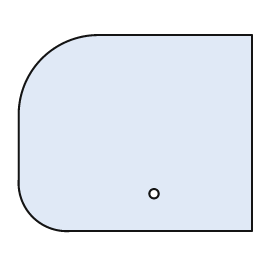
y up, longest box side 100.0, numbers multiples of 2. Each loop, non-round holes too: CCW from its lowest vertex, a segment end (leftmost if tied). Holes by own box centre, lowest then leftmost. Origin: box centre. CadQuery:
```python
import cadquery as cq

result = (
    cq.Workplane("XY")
    .moveTo(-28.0, -42.0)
    .lineTo(50.0, -42.0)
    .lineTo(50.0, 42.0)
    .lineTo(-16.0, 42.0)
    .threePointArc((-40.0, 32.0), (-50.0, 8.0))
    .lineTo(-50.0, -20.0)
    .threePointArc((-44.0, -36.0), (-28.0, -42.0))
    .close()
    .moveTo(8.0, -26.0)
    .circle(2.0)
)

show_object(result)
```